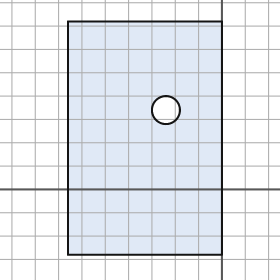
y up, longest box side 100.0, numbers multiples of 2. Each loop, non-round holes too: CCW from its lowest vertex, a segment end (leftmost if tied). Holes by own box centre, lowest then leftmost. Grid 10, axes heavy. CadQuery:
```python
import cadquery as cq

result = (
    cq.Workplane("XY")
    .moveTo(-66.0, -28.0)
    .lineTo(0.0, -28.0)
    .lineTo(0.0, 72.0)
    .lineTo(-66.0, 72.0)
    .close()
    .moveTo(-24.0, 34.0)
    .circle(6.0)
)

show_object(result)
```